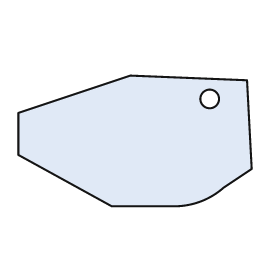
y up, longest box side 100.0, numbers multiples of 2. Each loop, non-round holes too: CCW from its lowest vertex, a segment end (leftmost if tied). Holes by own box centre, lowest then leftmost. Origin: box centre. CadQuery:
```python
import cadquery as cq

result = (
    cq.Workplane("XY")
    .moveTo(-10.0, -28.0)
    .lineTo(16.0, -28.0)
    .threePointArc((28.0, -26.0), (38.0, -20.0))
    .lineTo(50.0, -12.0)
    .lineTo(48.0, 26.0)
    .lineTo(-2.0, 28.0)
    .lineTo(-50.0, 12.0)
    .lineTo(-50.0, -6.0)
    .close()
    .moveTo(32.0, 18.0)
    .circle(4.0)
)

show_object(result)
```